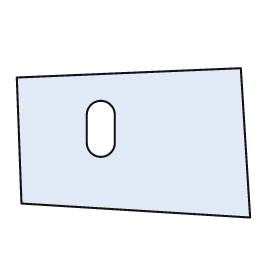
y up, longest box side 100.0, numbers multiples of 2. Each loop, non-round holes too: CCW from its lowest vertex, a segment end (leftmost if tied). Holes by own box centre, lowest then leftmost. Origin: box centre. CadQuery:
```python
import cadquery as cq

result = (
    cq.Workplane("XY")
    .moveTo(50.0, -32.0)
    .lineTo(46.0, 32.0)
    .lineTo(-50.0, 28.0)
    .lineTo(-48.0, -26.0)
    .close()
    .moveTo(-20.0, 0.0)
    .threePointArc((-14.0, -6.0), (-8.0, 0.0))
    .lineTo(-8.0, 12.0)
    .threePointArc((-14.0, 18.0), (-20.0, 12.0))
    .close()
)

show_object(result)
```